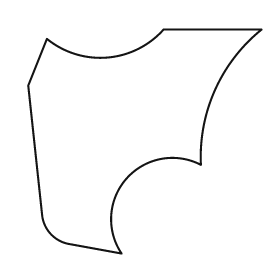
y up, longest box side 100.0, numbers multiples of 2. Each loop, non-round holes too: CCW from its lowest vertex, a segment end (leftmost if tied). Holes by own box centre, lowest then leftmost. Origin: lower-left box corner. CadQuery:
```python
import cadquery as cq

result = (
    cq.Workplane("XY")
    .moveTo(40.0, 0.0)
    .threePointArc((42.0, 32.0), (74.0, 38.0))
    .threePointArc((80.0, 70.0), (100.0, 96.0))
    .lineTo(58.0, 96.0)
    .threePointArc((34.0, 84.0), (8.0, 92.0))
    .lineTo(0.0, 72.0)
    .lineTo(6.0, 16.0)
    .threePointArc((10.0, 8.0), (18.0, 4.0))
    .close()
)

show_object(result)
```